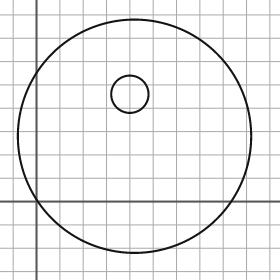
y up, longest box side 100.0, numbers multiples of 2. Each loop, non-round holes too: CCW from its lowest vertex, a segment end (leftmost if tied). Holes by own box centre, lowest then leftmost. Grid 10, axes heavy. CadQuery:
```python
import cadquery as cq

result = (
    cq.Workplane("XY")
    .moveTo(42.0, 28.0)
    .circle(50.0)
    .moveTo(40.0, 46.0)
    .circle(8.0)
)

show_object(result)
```